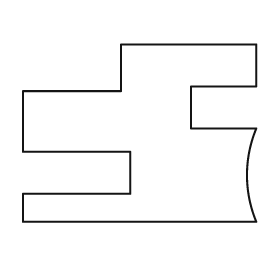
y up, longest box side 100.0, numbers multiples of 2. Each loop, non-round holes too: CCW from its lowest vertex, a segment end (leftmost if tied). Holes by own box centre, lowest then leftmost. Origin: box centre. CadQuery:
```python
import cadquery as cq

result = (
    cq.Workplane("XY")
    .moveTo(-50.0, -38.0)
    .lineTo(50.0, -38.0)
    .threePointArc((46.0, -18.0), (50.0, 2.0))
    .lineTo(22.0, 2.0)
    .lineTo(22.0, 20.0)
    .lineTo(50.0, 20.0)
    .lineTo(50.0, 38.0)
    .lineTo(-8.0, 38.0)
    .lineTo(-8.0, 18.0)
    .lineTo(-50.0, 18.0)
    .lineTo(-50.0, -8.0)
    .lineTo(-4.0, -8.0)
    .lineTo(-4.0, -26.0)
    .lineTo(-50.0, -26.0)
    .close()
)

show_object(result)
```